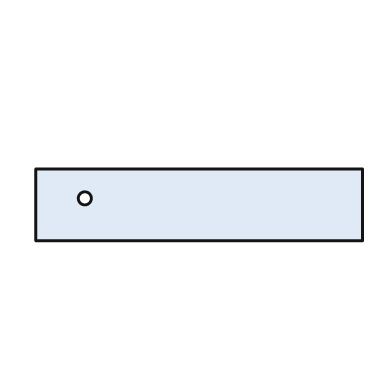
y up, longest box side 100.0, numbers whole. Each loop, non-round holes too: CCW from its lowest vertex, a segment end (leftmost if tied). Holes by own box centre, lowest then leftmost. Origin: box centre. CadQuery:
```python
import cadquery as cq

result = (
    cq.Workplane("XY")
    .moveTo(-50.0, -11.0)
    .lineTo(50.0, -11.0)
    .lineTo(50.0, 11.0)
    .lineTo(-50.0, 11.0)
    .close()
    .moveTo(-35.0, 2.0)
    .circle(2.0)
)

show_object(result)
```